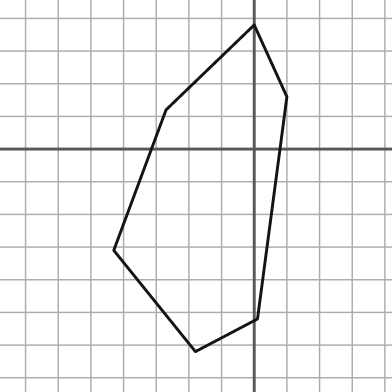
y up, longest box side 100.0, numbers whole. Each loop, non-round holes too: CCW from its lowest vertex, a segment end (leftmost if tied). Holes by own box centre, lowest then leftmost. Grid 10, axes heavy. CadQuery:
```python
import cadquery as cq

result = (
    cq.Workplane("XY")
    .moveTo(-18.0, -62.0)
    .lineTo(1.0, -52.0)
    .lineTo(10.0, 16.0)
    .lineTo(0.0, 38.0)
    .lineTo(-27.0, 12.0)
    .lineTo(-43.0, -31.0)
    .close()
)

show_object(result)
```